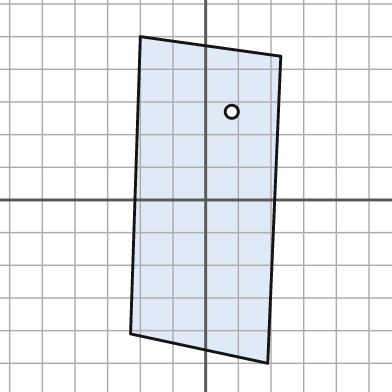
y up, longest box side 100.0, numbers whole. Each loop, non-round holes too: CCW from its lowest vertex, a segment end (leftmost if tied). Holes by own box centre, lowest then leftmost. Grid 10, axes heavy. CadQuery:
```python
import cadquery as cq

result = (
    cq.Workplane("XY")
    .moveTo(19.0, -50.0)
    .lineTo(23.0, 44.0)
    .lineTo(-20.0, 50.0)
    .lineTo(-23.0, -41.0)
    .close()
    .moveTo(8.0, 27.0)
    .circle(2.0)
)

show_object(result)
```